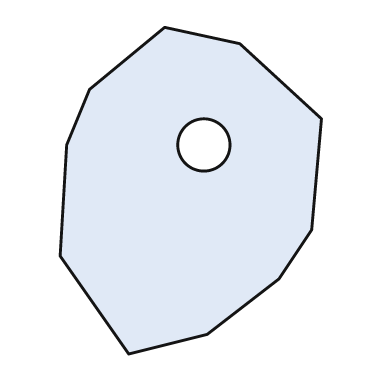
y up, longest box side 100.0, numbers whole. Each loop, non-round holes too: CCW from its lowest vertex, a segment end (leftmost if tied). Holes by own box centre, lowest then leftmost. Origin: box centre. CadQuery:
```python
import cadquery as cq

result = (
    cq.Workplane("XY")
    .moveTo(-19.0, -50.0)
    .lineTo(5.0, -44.0)
    .lineTo(27.0, -27.0)
    .lineTo(37.0, -12.0)
    .lineTo(40.0, 22.0)
    .lineTo(15.0, 45.0)
    .lineTo(-8.0, 50.0)
    .lineTo(-31.0, 31.0)
    .lineTo(-38.0, 14.0)
    .lineTo(-40.0, -20.0)
    .close()
    .moveTo(4.0, 14.0)
    .circle(8.0)
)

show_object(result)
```